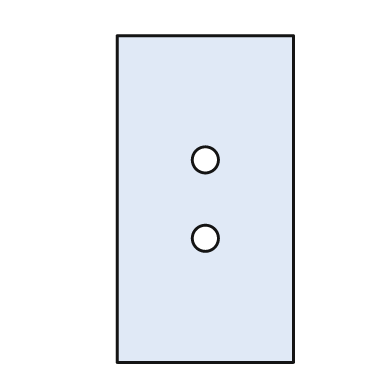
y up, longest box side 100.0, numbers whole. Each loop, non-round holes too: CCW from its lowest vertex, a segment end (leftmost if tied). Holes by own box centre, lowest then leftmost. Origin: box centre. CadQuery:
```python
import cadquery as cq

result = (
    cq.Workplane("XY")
    .moveTo(-27.0, -50.0)
    .lineTo(27.0, -50.0)
    .lineTo(27.0, 50.0)
    .lineTo(-27.0, 50.0)
    .close()
    .moveTo(0.0, -12.0)
    .circle(4.0)
    .moveTo(0.0, 12.0)
    .circle(4.0)
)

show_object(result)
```